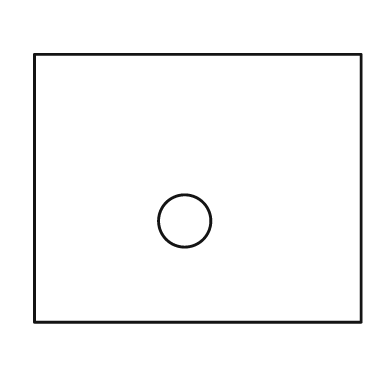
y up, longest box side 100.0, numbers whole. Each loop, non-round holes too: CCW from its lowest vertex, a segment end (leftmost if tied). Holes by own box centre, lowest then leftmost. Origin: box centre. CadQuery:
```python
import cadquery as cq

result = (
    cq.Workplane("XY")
    .moveTo(-50.0, -41.0)
    .lineTo(50.0, -41.0)
    .lineTo(50.0, 41.0)
    .lineTo(-50.0, 41.0)
    .close()
    .moveTo(-4.0, -10.0)
    .circle(8.0)
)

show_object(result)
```